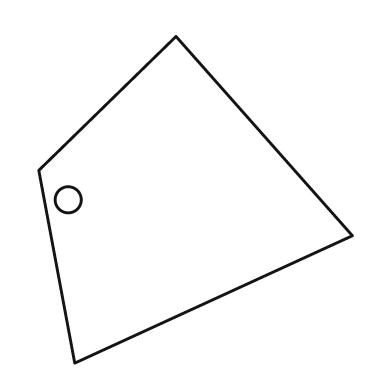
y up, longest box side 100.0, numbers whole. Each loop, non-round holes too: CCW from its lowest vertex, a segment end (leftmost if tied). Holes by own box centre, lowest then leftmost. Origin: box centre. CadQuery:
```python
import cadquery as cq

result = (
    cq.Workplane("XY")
    .moveTo(-37.0, -50.0)
    .lineTo(48.0, -11.0)
    .lineTo(-6.0, 50.0)
    .lineTo(-48.0, 9.0)
    .close()
    .moveTo(-39.0, 0.0)
    .circle(4.0)
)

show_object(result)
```